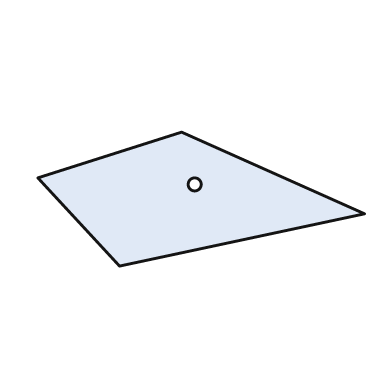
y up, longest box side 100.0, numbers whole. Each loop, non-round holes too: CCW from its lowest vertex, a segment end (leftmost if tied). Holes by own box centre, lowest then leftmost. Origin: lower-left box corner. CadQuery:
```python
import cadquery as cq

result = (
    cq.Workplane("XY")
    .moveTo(25.0, 0.0)
    .lineTo(100.0, 16.0)
    .lineTo(44.0, 41.0)
    .lineTo(0.0, 27.0)
    .close()
    .moveTo(48.0, 25.0)
    .circle(2.0)
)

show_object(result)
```